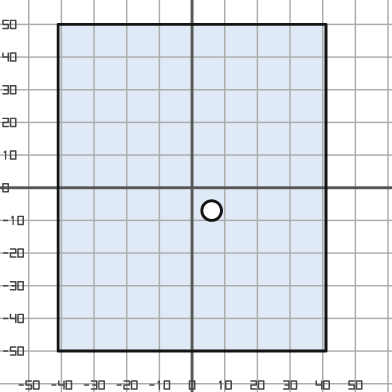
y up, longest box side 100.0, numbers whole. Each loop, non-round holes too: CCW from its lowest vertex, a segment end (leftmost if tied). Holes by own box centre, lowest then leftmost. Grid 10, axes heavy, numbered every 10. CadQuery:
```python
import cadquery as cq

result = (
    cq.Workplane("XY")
    .moveTo(-41.0, -50.0)
    .lineTo(41.0, -50.0)
    .lineTo(41.0, 50.0)
    .lineTo(-41.0, 50.0)
    .close()
    .moveTo(6.0, -7.0)
    .circle(3.0)
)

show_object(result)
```